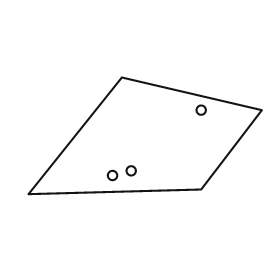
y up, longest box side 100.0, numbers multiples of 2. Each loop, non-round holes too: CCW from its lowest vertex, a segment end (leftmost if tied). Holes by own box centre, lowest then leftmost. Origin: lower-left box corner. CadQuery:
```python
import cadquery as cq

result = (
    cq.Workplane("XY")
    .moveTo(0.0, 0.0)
    .lineTo(74.0, 2.0)
    .lineTo(100.0, 36.0)
    .lineTo(40.0, 50.0)
    .close()
    .moveTo(36.0, 8.0)
    .circle(2.0)
    .moveTo(44.0, 10.0)
    .circle(2.0)
    .moveTo(74.0, 36.0)
    .circle(2.0)
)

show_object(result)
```